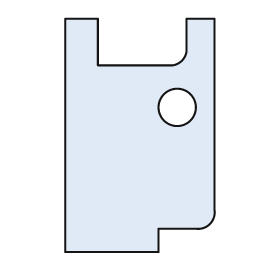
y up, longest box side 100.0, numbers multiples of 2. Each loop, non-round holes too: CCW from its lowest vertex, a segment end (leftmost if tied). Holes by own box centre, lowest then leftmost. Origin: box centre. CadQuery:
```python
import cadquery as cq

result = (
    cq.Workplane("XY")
    .moveTo(-32.0, -50.0)
    .lineTo(8.0, -50.0)
    .lineTo(8.0, -40.0)
    .lineTo(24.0, -40.0)
    .threePointArc((30.0, -38.0), (32.0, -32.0))
    .lineTo(32.0, 50.0)
    .lineTo(20.0, 50.0)
    .lineTo(20.0, 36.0)
    .threePointArc((18.0, 32.0), (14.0, 30.0))
    .lineTo(-18.0, 30.0)
    .lineTo(-18.0, 50.0)
    .lineTo(-32.0, 50.0)
    .close()
    .moveTo(16.0, 12.0)
    .circle(8.0)
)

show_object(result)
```